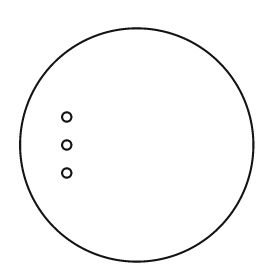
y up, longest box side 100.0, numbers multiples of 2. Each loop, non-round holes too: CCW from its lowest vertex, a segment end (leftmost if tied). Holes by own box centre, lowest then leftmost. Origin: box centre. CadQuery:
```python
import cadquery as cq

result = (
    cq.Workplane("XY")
    .moveTo(0.0, 0.0)
    .circle(50.0)
    .moveTo(-30.0, -12.0)
    .circle(2.0)
    .moveTo(-30.0, 0.0)
    .circle(2.0)
    .moveTo(-30.0, 12.0)
    .circle(2.0)
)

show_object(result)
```